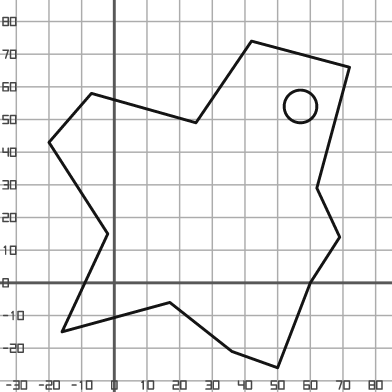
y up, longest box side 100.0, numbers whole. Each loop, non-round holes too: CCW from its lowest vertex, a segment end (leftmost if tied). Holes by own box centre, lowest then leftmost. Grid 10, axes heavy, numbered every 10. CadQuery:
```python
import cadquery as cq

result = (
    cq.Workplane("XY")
    .moveTo(50.0, -26.0)
    .lineTo(60.0, 0.0)
    .lineTo(69.0, 14.0)
    .lineTo(62.0, 29.0)
    .lineTo(72.0, 66.0)
    .lineTo(42.0, 74.0)
    .lineTo(25.0, 49.0)
    .lineTo(-7.0, 58.0)
    .lineTo(-20.0, 43.0)
    .lineTo(-2.0, 15.0)
    .lineTo(-16.0, -15.0)
    .lineTo(17.0, -6.0)
    .lineTo(36.0, -21.0)
    .close()
    .moveTo(57.0, 54.0)
    .circle(5.0)
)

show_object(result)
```